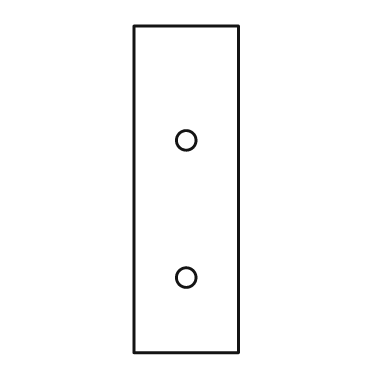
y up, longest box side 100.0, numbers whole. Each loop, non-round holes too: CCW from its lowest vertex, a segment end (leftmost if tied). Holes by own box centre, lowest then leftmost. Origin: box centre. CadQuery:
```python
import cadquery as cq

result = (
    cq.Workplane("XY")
    .moveTo(-16.0, -50.0)
    .lineTo(16.0, -50.0)
    .lineTo(16.0, 50.0)
    .lineTo(-16.0, 50.0)
    .close()
    .moveTo(0.0, -27.0)
    .circle(3.0)
    .moveTo(0.0, 15.0)
    .circle(3.0)
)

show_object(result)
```